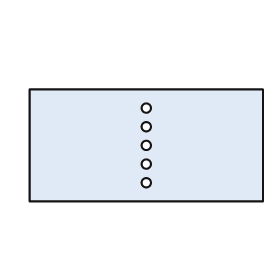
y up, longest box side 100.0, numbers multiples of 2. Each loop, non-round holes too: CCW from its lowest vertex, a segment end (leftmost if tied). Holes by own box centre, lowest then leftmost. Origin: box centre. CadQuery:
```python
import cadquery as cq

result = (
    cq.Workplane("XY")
    .moveTo(-50.0, -24.0)
    .lineTo(50.0, -24.0)
    .lineTo(50.0, 24.0)
    .lineTo(-50.0, 24.0)
    .close()
    .moveTo(0.0, -16.0)
    .circle(2.0)
    .moveTo(0.0, -8.0)
    .circle(2.0)
    .moveTo(0.0, 0.0)
    .circle(2.0)
    .moveTo(0.0, 8.0)
    .circle(2.0)
    .moveTo(0.0, 16.0)
    .circle(2.0)
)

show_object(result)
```